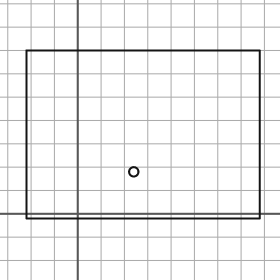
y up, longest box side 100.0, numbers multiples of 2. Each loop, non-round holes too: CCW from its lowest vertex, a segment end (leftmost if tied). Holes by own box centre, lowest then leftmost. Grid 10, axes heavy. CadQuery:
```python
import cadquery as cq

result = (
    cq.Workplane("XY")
    .moveTo(-22.0, -2.0)
    .lineTo(78.0, -2.0)
    .lineTo(78.0, 70.0)
    .lineTo(-22.0, 70.0)
    .close()
    .moveTo(24.0, 18.0)
    .circle(2.0)
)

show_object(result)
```